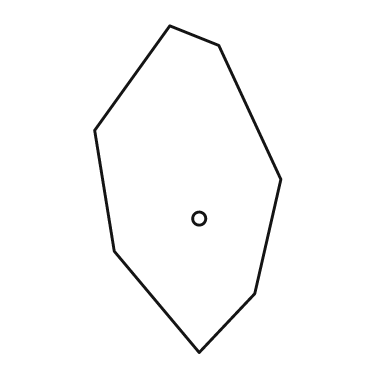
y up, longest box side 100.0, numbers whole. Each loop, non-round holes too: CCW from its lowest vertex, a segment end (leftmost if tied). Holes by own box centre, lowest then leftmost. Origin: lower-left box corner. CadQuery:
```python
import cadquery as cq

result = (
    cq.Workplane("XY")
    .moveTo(32.0, 0.0)
    .lineTo(49.0, 18.0)
    .lineTo(57.0, 53.0)
    .lineTo(38.0, 94.0)
    .lineTo(23.0, 100.0)
    .lineTo(0.0, 68.0)
    .lineTo(6.0, 31.0)
    .close()
    .moveTo(32.0, 41.0)
    .circle(2.0)
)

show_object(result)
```